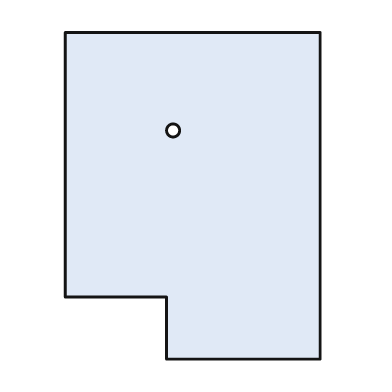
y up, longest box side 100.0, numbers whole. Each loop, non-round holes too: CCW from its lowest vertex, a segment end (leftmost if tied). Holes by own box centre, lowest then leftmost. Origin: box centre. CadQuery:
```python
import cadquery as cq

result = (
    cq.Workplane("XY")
    .moveTo(-8.0, -50.0)
    .lineTo(39.0, -50.0)
    .lineTo(39.0, 50.0)
    .lineTo(-39.0, 50.0)
    .lineTo(-39.0, -31.0)
    .lineTo(-8.0, -31.0)
    .close()
    .moveTo(-6.0, 20.0)
    .circle(2.0)
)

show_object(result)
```